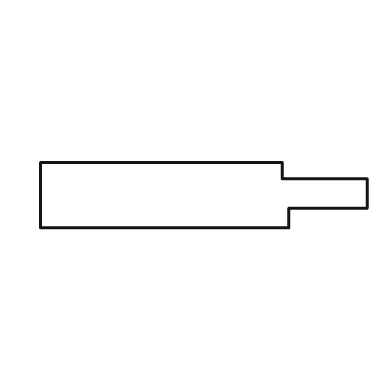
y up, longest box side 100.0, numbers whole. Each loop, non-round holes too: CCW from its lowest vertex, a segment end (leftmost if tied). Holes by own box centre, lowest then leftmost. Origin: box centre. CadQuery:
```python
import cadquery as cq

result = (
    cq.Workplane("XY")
    .moveTo(-50.0, -10.0)
    .lineTo(26.0, -10.0)
    .lineTo(26.0, -4.0)
    .lineTo(50.0, -4.0)
    .lineTo(50.0, 5.0)
    .lineTo(24.0, 5.0)
    .lineTo(24.0, 10.0)
    .lineTo(-50.0, 10.0)
    .close()
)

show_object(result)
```